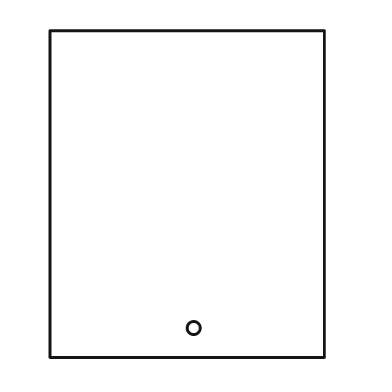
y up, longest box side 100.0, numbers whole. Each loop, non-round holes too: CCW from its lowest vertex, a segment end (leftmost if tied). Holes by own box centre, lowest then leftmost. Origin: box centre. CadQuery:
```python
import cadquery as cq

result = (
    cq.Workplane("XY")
    .moveTo(-42.0, -50.0)
    .lineTo(42.0, -50.0)
    .lineTo(42.0, 50.0)
    .lineTo(-42.0, 50.0)
    .close()
    .moveTo(2.0, -41.0)
    .circle(2.0)
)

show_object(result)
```